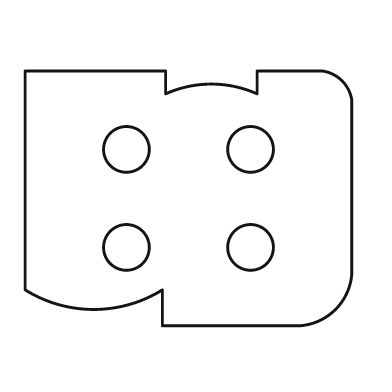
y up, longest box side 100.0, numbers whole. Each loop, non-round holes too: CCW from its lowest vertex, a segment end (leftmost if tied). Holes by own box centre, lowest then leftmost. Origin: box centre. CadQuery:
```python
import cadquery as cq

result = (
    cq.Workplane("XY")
    .moveTo(-8.0, -39.0)
    .lineTo(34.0, -39.0)
    .threePointArc((45.0, -34.0), (50.0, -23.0))
    .lineTo(50.0, 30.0)
    .threePointArc((47.0, 36.0), (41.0, 39.0))
    .lineTo(21.0, 39.0)
    .lineTo(21.0, 32.0)
    .threePointArc((7.0, 35.0), (-7.0, 32.0))
    .lineTo(-7.0, 39.0)
    .lineTo(-50.0, 39.0)
    .lineTo(-50.0, -28.0)
    .threePointArc((-29.0, -34.0), (-8.0, -28.0))
    .close()
    .moveTo(-19.0, -15.0)
    .circle(7.0)
    .moveTo(19.0, -15.0)
    .circle(7.0)
    .moveTo(-19.0, 15.0)
    .circle(7.0)
    .moveTo(19.0, 15.0)
    .circle(7.0)
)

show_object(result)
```